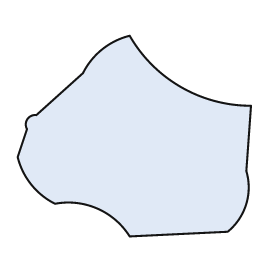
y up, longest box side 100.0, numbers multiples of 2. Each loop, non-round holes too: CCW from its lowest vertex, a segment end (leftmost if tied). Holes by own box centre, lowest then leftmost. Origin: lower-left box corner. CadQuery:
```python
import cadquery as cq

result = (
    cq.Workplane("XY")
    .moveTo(48.0, 0.0)
    .lineTo(90.0, 2.0)
    .threePointArc((98.0, 14.0), (98.0, 28.0))
    .lineTo(100.0, 56.0)
    .threePointArc((70.0, 64.0), (48.0, 86.0))
    .threePointArc((36.0, 80.0), (28.0, 70.0))
    .lineTo(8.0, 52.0)
    .threePointArc((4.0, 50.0), (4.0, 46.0))
    .lineTo(0.0, 34.0)
    .threePointArc((6.0, 22.0), (16.0, 14.0))
    .threePointArc((34.0, 12.0), (48.0, 0.0))
    .close()
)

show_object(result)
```